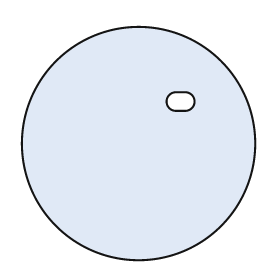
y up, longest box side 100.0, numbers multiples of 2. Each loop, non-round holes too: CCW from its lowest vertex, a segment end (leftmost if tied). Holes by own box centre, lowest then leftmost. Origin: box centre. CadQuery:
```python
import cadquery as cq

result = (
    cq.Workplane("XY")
    .moveTo(0.0, 0.0)
    .circle(50.0)
    .moveTo(16.0, 14.0)
    .lineTo(20.0, 14.0)
    .threePointArc((24.0, 18.0), (20.0, 22.0))
    .lineTo(16.0, 22.0)
    .threePointArc((12.0, 18.0), (16.0, 14.0))
    .close()
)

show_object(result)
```